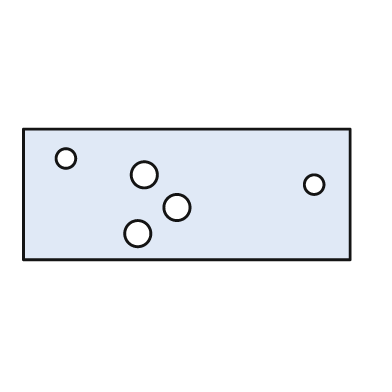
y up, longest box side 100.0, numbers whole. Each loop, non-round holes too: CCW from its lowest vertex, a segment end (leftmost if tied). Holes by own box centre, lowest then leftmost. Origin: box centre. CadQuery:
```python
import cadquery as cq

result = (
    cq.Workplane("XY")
    .moveTo(-50.0, -20.0)
    .lineTo(50.0, -20.0)
    .lineTo(50.0, 20.0)
    .lineTo(-50.0, 20.0)
    .close()
    .moveTo(-15.0, -12.0)
    .circle(4.0)
    .moveTo(-3.0, -4.0)
    .circle(4.0)
    .moveTo(39.0, 3.0)
    .circle(3.0)
    .moveTo(-13.0, 6.0)
    .circle(4.0)
    .moveTo(-37.0, 11.0)
    .circle(3.0)
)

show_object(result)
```